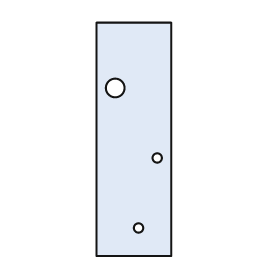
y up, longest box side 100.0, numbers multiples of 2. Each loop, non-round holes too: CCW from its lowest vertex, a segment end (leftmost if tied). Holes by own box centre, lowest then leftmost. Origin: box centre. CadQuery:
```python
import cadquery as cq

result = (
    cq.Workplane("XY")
    .moveTo(-16.0, -50.0)
    .lineTo(16.0, -50.0)
    .lineTo(16.0, 50.0)
    .lineTo(-16.0, 50.0)
    .close()
    .moveTo(2.0, -38.0)
    .circle(2.0)
    .moveTo(10.0, -8.0)
    .circle(2.0)
    .moveTo(-8.0, 22.0)
    .circle(4.0)
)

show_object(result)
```